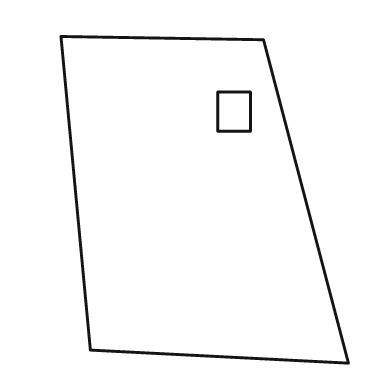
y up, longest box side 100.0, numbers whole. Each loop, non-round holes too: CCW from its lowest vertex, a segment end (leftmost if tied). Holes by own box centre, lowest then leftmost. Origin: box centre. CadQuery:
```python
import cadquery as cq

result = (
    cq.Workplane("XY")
    .moveTo(44.0, -50.0)
    .lineTo(18.0, 49.0)
    .lineTo(-44.0, 50.0)
    .lineTo(-35.0, -46.0)
    .close()
    .moveTo(4.0, 21.0)
    .lineTo(14.0, 21.0)
    .lineTo(14.0, 33.0)
    .lineTo(4.0, 33.0)
    .close()
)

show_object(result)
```